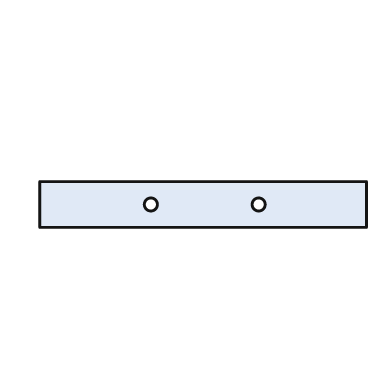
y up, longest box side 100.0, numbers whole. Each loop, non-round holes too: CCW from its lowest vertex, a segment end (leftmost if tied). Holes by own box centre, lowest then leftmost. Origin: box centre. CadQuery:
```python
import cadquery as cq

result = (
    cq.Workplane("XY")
    .moveTo(-50.0, -7.0)
    .lineTo(50.0, -7.0)
    .lineTo(50.0, 7.0)
    .lineTo(-50.0, 7.0)
    .close()
    .moveTo(-16.0, 0.0)
    .circle(2.0)
    .moveTo(17.0, 0.0)
    .circle(2.0)
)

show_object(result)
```